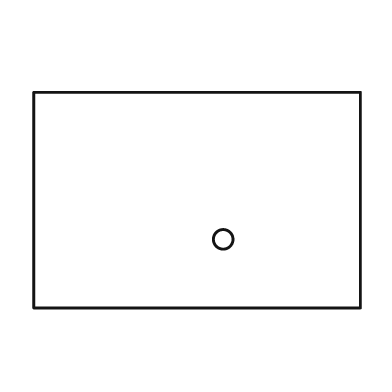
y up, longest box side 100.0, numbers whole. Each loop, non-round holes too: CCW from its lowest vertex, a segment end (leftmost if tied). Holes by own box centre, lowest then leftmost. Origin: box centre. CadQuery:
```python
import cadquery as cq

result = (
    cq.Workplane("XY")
    .moveTo(-50.0, -33.0)
    .lineTo(50.0, -33.0)
    .lineTo(50.0, 33.0)
    .lineTo(-50.0, 33.0)
    .close()
    .moveTo(8.0, -12.0)
    .circle(3.0)
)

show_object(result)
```